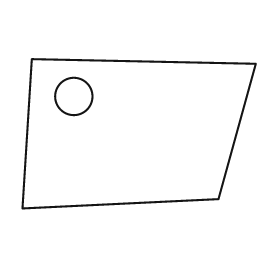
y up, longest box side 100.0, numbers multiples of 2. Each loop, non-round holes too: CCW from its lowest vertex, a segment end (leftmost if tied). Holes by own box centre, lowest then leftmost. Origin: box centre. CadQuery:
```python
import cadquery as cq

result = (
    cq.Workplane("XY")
    .moveTo(-50.0, -32.0)
    .lineTo(34.0, -28.0)
    .lineTo(50.0, 30.0)
    .lineTo(-46.0, 32.0)
    .close()
    .moveTo(-28.0, 16.0)
    .circle(8.0)
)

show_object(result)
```